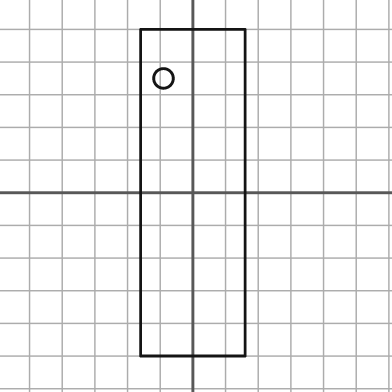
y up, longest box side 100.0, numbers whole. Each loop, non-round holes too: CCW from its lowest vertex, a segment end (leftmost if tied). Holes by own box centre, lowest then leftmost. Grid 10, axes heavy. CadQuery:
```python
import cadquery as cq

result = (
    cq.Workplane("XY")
    .moveTo(-16.0, -50.0)
    .lineTo(16.0, -50.0)
    .lineTo(16.0, 50.0)
    .lineTo(-16.0, 50.0)
    .close()
    .moveTo(-9.0, 35.0)
    .circle(3.0)
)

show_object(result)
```